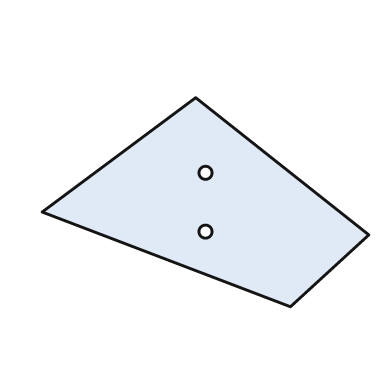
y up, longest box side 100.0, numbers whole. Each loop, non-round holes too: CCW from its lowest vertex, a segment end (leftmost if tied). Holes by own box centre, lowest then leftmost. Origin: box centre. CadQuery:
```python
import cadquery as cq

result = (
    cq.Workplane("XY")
    .moveTo(26.0, -32.0)
    .lineTo(50.0, -10.0)
    .lineTo(-3.0, 32.0)
    .lineTo(-50.0, -3.0)
    .close()
    .moveTo(0.0, -9.0)
    .circle(2.0)
    .moveTo(0.0, 9.0)
    .circle(2.0)
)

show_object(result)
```